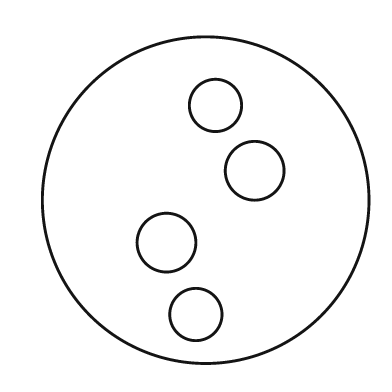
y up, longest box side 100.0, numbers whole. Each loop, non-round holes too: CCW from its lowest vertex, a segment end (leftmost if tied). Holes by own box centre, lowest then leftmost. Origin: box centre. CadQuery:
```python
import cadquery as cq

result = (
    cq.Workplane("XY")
    .moveTo(0.0, 0.0)
    .circle(50.0)
    .moveTo(-3.0, -35.0)
    .circle(8.0)
    .moveTo(-12.0, -13.0)
    .circle(9.0)
    .moveTo(15.0, 9.0)
    .circle(9.0)
    .moveTo(3.0, 29.0)
    .circle(8.0)
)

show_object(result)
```